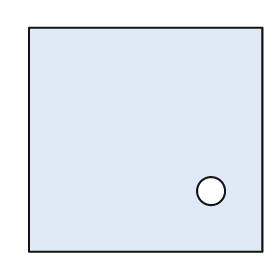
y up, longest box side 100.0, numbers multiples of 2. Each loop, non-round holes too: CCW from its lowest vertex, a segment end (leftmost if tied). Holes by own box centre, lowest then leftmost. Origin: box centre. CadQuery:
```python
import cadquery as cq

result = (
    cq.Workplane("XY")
    .moveTo(-50.0, -48.0)
    .lineTo(50.0, -48.0)
    .lineTo(50.0, 48.0)
    .lineTo(-50.0, 48.0)
    .close()
    .moveTo(28.0, -22.0)
    .circle(6.0)
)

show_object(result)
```